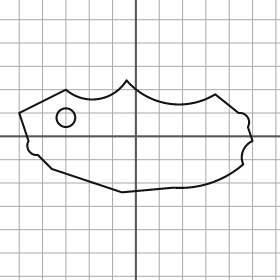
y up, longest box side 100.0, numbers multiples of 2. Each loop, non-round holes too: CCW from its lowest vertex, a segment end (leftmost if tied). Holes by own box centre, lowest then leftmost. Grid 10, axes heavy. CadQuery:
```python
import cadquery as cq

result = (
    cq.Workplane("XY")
    .moveTo(-6.0, -24.0)
    .lineTo(16.0, -22.0)
    .threePointArc((32.0, -20.0), (46.0, -12.0))
    .threePointArc((46.0, -6.0), (50.0, -2.0))
    .lineTo(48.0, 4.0)
    .threePointArc((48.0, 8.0), (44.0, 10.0))
    .lineTo(34.0, 18.0)
    .threePointArc((14.0, 14.0), (-4.0, 24.0))
    .threePointArc((-16.0, 16.0), (-30.0, 20.0))
    .lineTo(-50.0, 10.0)
    .lineTo(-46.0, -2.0)
    .threePointArc((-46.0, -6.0), (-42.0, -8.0))
    .lineTo(-36.0, -14.0)
    .close()
    .moveTo(-30.0, 8.0)
    .circle(4.0)
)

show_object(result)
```